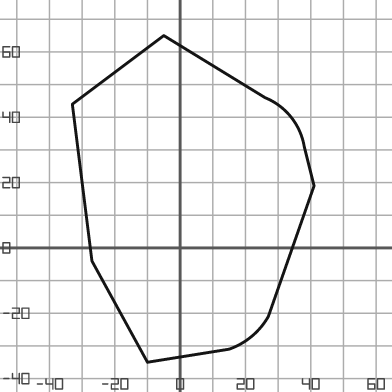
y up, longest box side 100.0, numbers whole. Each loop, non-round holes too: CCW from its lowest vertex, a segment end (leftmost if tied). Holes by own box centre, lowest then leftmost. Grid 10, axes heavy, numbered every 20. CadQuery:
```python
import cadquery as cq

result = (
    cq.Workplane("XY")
    .moveTo(-10.0, -35.0)
    .lineTo(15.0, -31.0)
    .threePointArc((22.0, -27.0), (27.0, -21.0))
    .lineTo(41.0, 19.0)
    .lineTo(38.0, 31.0)
    .threePointArc((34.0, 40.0), (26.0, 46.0))
    .lineTo(-5.0, 65.0)
    .lineTo(-33.0, 44.0)
    .lineTo(-27.0, -4.0)
    .close()
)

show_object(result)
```